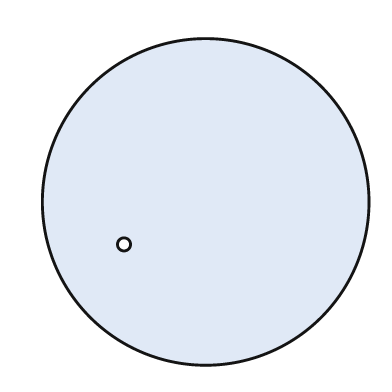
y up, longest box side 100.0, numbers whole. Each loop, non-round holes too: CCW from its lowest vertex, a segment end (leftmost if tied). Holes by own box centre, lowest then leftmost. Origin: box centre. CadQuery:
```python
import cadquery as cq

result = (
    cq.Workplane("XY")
    .moveTo(0.0, 0.0)
    .circle(50.0)
    .moveTo(-25.0, -13.0)
    .circle(2.0)
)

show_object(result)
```